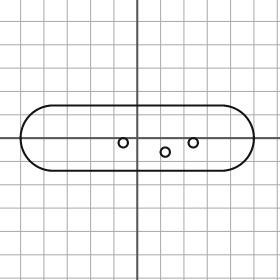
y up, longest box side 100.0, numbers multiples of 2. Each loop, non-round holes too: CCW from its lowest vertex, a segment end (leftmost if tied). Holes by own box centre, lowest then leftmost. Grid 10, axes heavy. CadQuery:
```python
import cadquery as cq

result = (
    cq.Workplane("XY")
    .moveTo(-36.0, -14.0)
    .lineTo(36.0, -14.0)
    .threePointArc((50.0, 0.0), (36.0, 14.0))
    .lineTo(-36.0, 14.0)
    .threePointArc((-50.0, 0.0), (-36.0, -14.0))
    .close()
    .moveTo(12.0, -6.0)
    .circle(2.0)
    .moveTo(-6.0, -2.0)
    .circle(2.0)
    .moveTo(24.0, -2.0)
    .circle(2.0)
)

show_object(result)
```